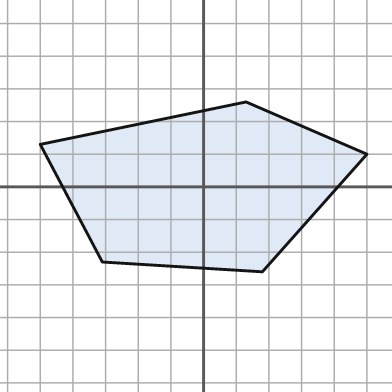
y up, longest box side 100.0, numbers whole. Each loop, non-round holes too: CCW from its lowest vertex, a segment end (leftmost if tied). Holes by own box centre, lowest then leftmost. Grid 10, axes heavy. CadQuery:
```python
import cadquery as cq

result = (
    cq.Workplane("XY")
    .moveTo(18.0, -26.0)
    .lineTo(50.0, 10.0)
    .lineTo(13.0, 26.0)
    .lineTo(-50.0, 13.0)
    .lineTo(-31.0, -23.0)
    .close()
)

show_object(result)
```